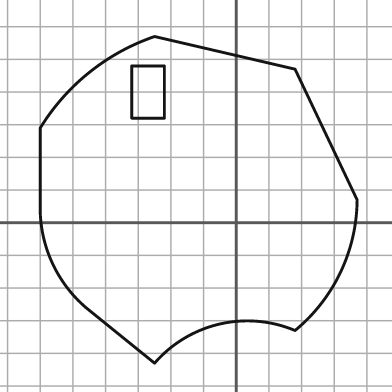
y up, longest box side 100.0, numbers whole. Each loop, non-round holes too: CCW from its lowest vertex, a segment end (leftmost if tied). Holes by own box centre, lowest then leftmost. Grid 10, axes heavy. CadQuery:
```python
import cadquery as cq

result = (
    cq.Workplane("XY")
    .moveTo(-25.0, -43.0)
    .threePointArc((-5.0, -31.0), (18.0, -33.0))
    .threePointArc((32.0, -15.0), (37.0, 7.0))
    .lineTo(18.0, 47.0)
    .lineTo(-25.0, 57.0)
    .threePointArc((-45.0, 46.0), (-60.0, 29.0))
    .lineTo(-60.0, 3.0)
    .threePointArc((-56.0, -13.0), (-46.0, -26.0))
    .close()
    .moveTo(-32.0, 32.0)
    .lineTo(-22.0, 32.0)
    .lineTo(-22.0, 48.0)
    .lineTo(-32.0, 48.0)
    .close()
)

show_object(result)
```